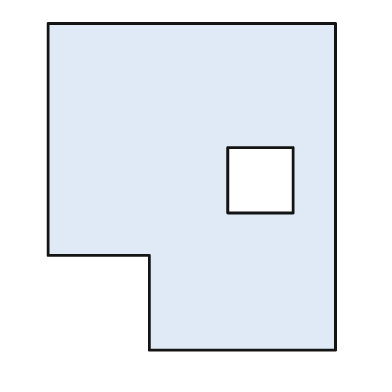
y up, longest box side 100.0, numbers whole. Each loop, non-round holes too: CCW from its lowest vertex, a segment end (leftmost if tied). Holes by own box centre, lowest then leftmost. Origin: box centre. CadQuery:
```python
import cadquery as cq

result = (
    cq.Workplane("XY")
    .moveTo(-13.0, -50.0)
    .lineTo(44.0, -50.0)
    .lineTo(44.0, 50.0)
    .lineTo(-44.0, 50.0)
    .lineTo(-44.0, -21.0)
    .lineTo(-13.0, -21.0)
    .close()
    .moveTo(11.0, -8.0)
    .lineTo(31.0, -8.0)
    .lineTo(31.0, 12.0)
    .lineTo(11.0, 12.0)
    .close()
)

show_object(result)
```